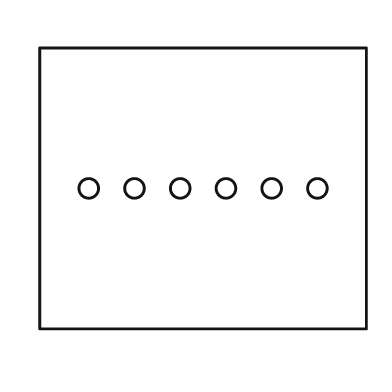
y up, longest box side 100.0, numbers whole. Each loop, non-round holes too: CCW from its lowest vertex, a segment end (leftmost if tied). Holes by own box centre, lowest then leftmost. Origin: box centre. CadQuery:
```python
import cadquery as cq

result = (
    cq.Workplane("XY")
    .moveTo(-50.0, -43.0)
    .lineTo(50.0, -43.0)
    .lineTo(50.0, 43.0)
    .lineTo(-50.0, 43.0)
    .close()
    .moveTo(-35.0, 0.0)
    .circle(3.0)
    .moveTo(-21.0, 0.0)
    .circle(3.0)
    .moveTo(-7.0, 0.0)
    .circle(3.0)
    .moveTo(7.0, 0.0)
    .circle(3.0)
    .moveTo(21.0, 0.0)
    .circle(3.0)
    .moveTo(35.0, 0.0)
    .circle(3.0)
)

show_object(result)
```